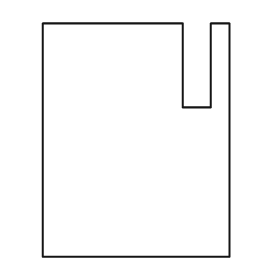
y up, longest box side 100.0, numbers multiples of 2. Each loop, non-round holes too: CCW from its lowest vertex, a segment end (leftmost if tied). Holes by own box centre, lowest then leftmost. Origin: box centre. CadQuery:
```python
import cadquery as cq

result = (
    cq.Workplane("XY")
    .moveTo(-40.0, -50.0)
    .lineTo(40.0, -50.0)
    .lineTo(40.0, 50.0)
    .lineTo(32.0, 50.0)
    .lineTo(32.0, 14.0)
    .lineTo(20.0, 14.0)
    .lineTo(20.0, 50.0)
    .lineTo(-40.0, 50.0)
    .close()
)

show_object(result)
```